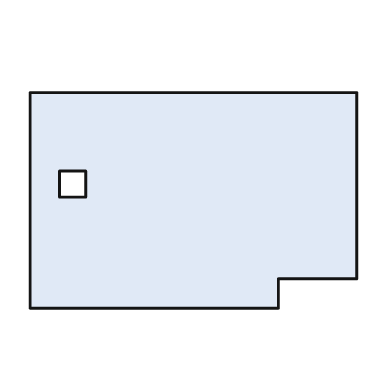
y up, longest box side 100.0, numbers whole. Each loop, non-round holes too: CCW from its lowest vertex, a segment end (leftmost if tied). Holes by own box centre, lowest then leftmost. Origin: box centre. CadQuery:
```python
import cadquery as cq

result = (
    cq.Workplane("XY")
    .moveTo(-50.0, -33.0)
    .lineTo(26.0, -33.0)
    .lineTo(26.0, -24.0)
    .lineTo(50.0, -24.0)
    .lineTo(50.0, 33.0)
    .lineTo(-50.0, 33.0)
    .close()
    .moveTo(-41.0, 1.0)
    .lineTo(-33.0, 1.0)
    .lineTo(-33.0, 9.0)
    .lineTo(-41.0, 9.0)
    .close()
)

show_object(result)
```